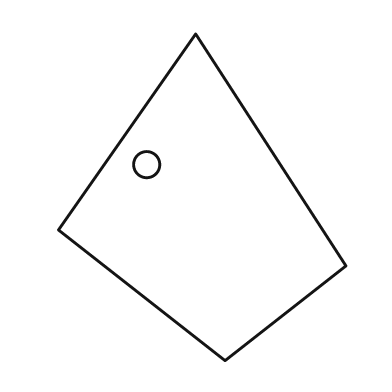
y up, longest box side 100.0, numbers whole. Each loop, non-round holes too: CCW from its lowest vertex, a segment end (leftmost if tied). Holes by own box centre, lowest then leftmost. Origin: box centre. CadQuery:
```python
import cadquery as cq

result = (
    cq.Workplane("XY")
    .moveTo(7.0, -50.0)
    .lineTo(44.0, -21.0)
    .lineTo(-2.0, 50.0)
    .lineTo(-44.0, -10.0)
    .close()
    .moveTo(-17.0, 10.0)
    .circle(4.0)
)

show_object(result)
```